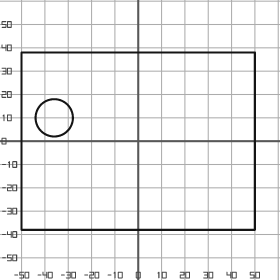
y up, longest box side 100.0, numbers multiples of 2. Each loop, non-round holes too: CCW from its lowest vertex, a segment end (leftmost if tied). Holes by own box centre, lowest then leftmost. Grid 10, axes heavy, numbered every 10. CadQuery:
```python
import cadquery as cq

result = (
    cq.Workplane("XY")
    .moveTo(-50.0, -38.0)
    .lineTo(50.0, -38.0)
    .lineTo(50.0, 38.0)
    .lineTo(-50.0, 38.0)
    .close()
    .moveTo(-36.0, 10.0)
    .circle(8.0)
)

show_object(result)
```